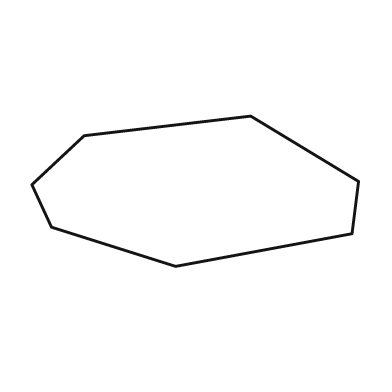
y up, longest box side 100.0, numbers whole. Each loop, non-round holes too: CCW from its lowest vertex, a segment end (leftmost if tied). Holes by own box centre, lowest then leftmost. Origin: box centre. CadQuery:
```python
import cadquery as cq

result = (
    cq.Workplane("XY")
    .moveTo(-6.0, -23.0)
    .lineTo(48.0, -13.0)
    .lineTo(50.0, 3.0)
    .lineTo(17.0, 23.0)
    .lineTo(-34.0, 17.0)
    .lineTo(-50.0, 2.0)
    .lineTo(-44.0, -11.0)
    .close()
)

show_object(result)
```